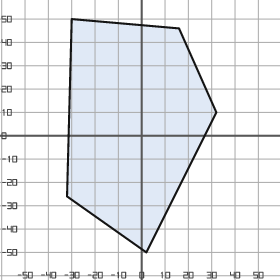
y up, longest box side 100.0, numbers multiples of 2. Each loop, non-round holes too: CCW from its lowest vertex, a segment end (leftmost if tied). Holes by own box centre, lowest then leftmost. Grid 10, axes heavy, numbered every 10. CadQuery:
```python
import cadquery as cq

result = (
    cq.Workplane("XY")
    .moveTo(2.0, -50.0)
    .lineTo(32.0, 10.0)
    .lineTo(16.0, 46.0)
    .lineTo(-30.0, 50.0)
    .lineTo(-32.0, -26.0)
    .close()
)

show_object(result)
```